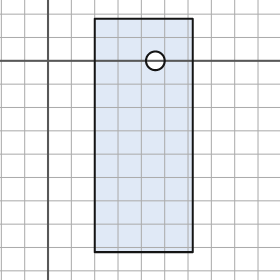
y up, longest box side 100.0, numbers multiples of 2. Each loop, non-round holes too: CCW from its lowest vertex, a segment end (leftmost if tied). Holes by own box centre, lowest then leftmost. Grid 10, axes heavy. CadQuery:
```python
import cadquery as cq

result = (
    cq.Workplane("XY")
    .moveTo(20.0, -82.0)
    .lineTo(62.0, -82.0)
    .lineTo(62.0, 18.0)
    .lineTo(20.0, 18.0)
    .close()
    .moveTo(46.0, 0.0)
    .circle(4.0)
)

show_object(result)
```